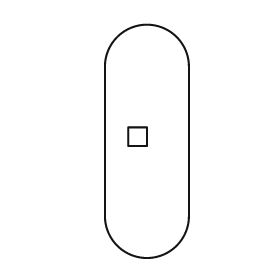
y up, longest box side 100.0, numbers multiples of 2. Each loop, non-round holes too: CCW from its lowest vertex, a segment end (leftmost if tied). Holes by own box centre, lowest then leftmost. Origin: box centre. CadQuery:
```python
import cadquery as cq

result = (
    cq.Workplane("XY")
    .moveTo(-18.0, -32.0)
    .threePointArc((0.0, -50.0), (18.0, -32.0))
    .lineTo(18.0, 32.0)
    .threePointArc((0.0, 50.0), (-18.0, 32.0))
    .close()
    .moveTo(-8.0, -2.0)
    .lineTo(0.0, -2.0)
    .lineTo(0.0, 6.0)
    .lineTo(-8.0, 6.0)
    .close()
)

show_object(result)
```